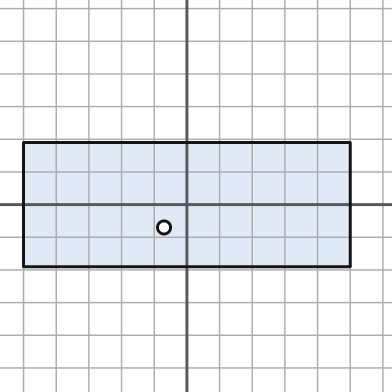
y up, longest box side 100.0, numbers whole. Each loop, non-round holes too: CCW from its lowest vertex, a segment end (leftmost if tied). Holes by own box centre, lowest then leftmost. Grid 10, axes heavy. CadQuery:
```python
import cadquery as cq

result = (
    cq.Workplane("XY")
    .moveTo(-50.0, -19.0)
    .lineTo(50.0, -19.0)
    .lineTo(50.0, 19.0)
    .lineTo(-50.0, 19.0)
    .close()
    .moveTo(-7.0, -7.0)
    .circle(2.0)
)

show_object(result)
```